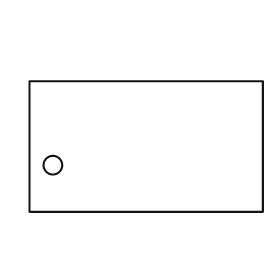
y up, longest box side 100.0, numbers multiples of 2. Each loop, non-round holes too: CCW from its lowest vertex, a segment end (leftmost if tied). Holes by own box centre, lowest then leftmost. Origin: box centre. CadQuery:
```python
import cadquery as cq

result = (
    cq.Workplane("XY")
    .moveTo(-50.0, -28.0)
    .lineTo(50.0, -28.0)
    .lineTo(50.0, 28.0)
    .lineTo(-50.0, 28.0)
    .close()
    .moveTo(-40.0, -8.0)
    .circle(4.0)
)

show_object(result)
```